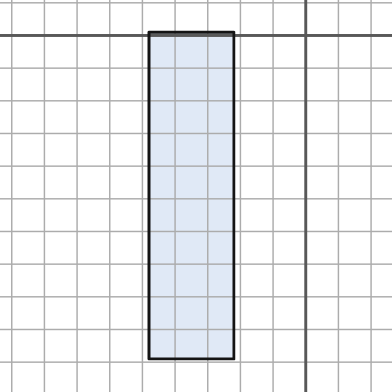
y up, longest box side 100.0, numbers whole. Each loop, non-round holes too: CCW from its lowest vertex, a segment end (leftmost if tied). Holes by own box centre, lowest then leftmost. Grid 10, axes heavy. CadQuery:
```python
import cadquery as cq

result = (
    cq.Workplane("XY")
    .moveTo(-48.0, -99.0)
    .lineTo(-22.0, -99.0)
    .lineTo(-22.0, 1.0)
    .lineTo(-48.0, 1.0)
    .close()
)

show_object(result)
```